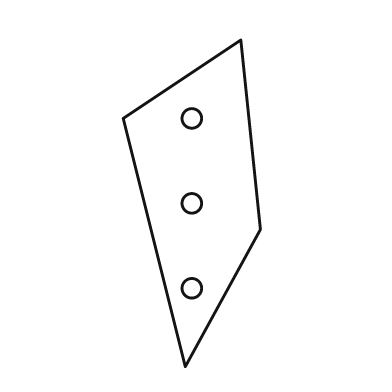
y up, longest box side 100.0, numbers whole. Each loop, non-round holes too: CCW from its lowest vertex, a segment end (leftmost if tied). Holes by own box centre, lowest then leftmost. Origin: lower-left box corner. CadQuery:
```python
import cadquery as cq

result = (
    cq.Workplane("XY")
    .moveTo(19.0, 0.0)
    .lineTo(42.0, 42.0)
    .lineTo(36.0, 100.0)
    .lineTo(0.0, 76.0)
    .close()
    .moveTo(21.0, 24.0)
    .circle(3.0)
    .moveTo(21.0, 50.0)
    .circle(3.0)
    .moveTo(21.0, 76.0)
    .circle(3.0)
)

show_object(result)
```